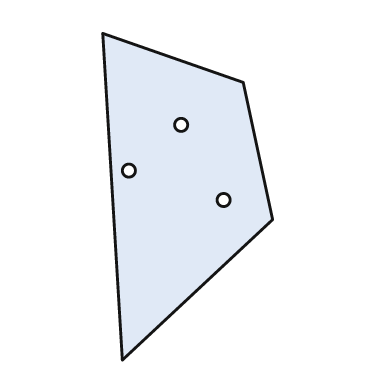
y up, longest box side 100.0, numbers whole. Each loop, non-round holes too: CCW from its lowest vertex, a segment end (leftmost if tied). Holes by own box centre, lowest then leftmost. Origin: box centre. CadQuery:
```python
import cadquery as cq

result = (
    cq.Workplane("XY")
    .moveTo(-20.0, -50.0)
    .lineTo(26.0, -7.0)
    .lineTo(17.0, 35.0)
    .lineTo(-26.0, 50.0)
    .close()
    .moveTo(11.0, -1.0)
    .circle(2.0)
    .moveTo(-18.0, 8.0)
    .circle(2.0)
    .moveTo(-2.0, 22.0)
    .circle(2.0)
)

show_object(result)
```